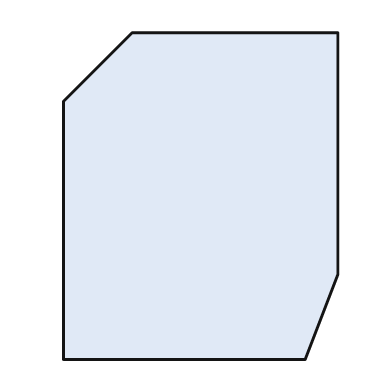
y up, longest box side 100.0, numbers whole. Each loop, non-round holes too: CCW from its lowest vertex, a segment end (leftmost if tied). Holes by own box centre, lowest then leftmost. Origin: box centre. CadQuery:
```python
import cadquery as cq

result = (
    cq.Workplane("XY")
    .moveTo(-42.0, -50.0)
    .lineTo(32.0, -50.0)
    .lineTo(42.0, -24.0)
    .lineTo(42.0, 50.0)
    .lineTo(-21.0, 50.0)
    .lineTo(-42.0, 29.0)
    .close()
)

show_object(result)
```